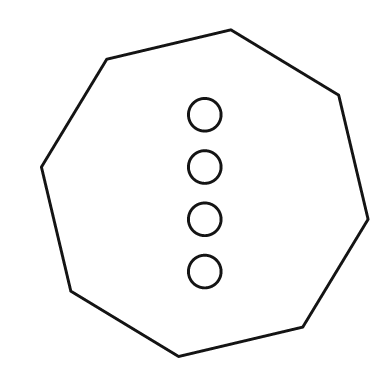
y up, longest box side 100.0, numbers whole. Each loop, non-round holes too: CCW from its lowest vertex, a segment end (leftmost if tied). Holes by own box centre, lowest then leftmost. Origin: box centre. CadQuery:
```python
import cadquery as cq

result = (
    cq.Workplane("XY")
    .moveTo(-8.0, -50.0)
    .lineTo(30.0, -41.0)
    .lineTo(50.0, -8.0)
    .lineTo(41.0, 30.0)
    .lineTo(8.0, 50.0)
    .lineTo(-30.0, 41.0)
    .lineTo(-50.0, 8.0)
    .lineTo(-41.0, -30.0)
    .close()
    .moveTo(0.0, -24.0)
    .circle(5.0)
    .moveTo(0.0, -8.0)
    .circle(5.0)
    .moveTo(0.0, 8.0)
    .circle(5.0)
    .moveTo(0.0, 24.0)
    .circle(5.0)
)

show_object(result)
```